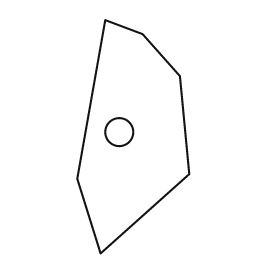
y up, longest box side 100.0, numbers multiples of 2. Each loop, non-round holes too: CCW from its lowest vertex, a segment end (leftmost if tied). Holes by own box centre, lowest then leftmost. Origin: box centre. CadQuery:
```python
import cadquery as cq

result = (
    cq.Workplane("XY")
    .moveTo(-14.0, -50.0)
    .lineTo(24.0, -16.0)
    .lineTo(20.0, 26.0)
    .lineTo(4.0, 44.0)
    .lineTo(-12.0, 50.0)
    .lineTo(-24.0, -18.0)
    .close()
    .moveTo(-6.0, 2.0)
    .circle(6.0)
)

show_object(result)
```